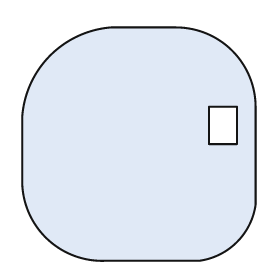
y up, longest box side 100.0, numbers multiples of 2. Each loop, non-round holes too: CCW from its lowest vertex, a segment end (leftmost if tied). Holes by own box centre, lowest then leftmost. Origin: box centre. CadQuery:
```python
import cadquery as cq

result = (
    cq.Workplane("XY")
    .moveTo(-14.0, -50.0)
    .lineTo(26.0, -50.0)
    .threePointArc((42.0, -42.0), (50.0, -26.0))
    .lineTo(50.0, 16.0)
    .threePointArc((40.0, 40.0), (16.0, 50.0))
    .lineTo(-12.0, 50.0)
    .threePointArc((-38.0, 38.0), (-50.0, 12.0))
    .lineTo(-50.0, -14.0)
    .threePointArc((-40.0, -40.0), (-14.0, -50.0))
    .close()
    .moveTo(30.0, 0.0)
    .lineTo(42.0, 0.0)
    .lineTo(42.0, 16.0)
    .lineTo(30.0, 16.0)
    .close()
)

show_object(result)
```